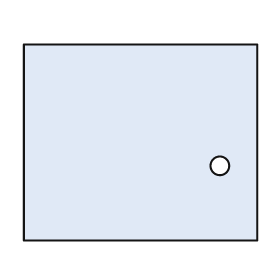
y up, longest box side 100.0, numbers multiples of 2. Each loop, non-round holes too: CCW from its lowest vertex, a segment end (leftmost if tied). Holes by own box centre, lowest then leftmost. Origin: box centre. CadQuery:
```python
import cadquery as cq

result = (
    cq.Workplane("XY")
    .moveTo(-50.0, -42.0)
    .lineTo(50.0, -42.0)
    .lineTo(50.0, 42.0)
    .lineTo(-50.0, 42.0)
    .close()
    .moveTo(34.0, -10.0)
    .circle(4.0)
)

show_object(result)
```